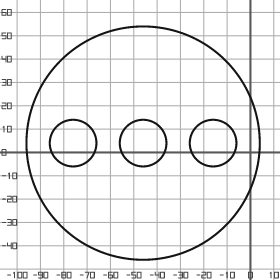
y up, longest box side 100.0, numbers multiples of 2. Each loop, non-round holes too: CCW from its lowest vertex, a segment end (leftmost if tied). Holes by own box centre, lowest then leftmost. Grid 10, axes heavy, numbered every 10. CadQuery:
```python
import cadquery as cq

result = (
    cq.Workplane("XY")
    .moveTo(-46.0, 4.0)
    .circle(50.0)
    .moveTo(-76.0, 4.0)
    .circle(10.0)
    .moveTo(-46.0, 4.0)
    .circle(10.0)
    .moveTo(-16.0, 4.0)
    .circle(10.0)
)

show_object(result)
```